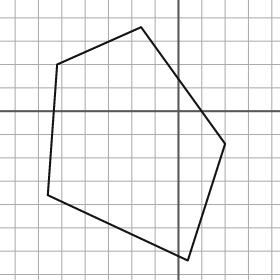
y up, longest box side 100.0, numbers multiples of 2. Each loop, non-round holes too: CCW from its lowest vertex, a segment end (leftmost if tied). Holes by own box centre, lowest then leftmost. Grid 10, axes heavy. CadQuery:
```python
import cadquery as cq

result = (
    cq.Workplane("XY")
    .moveTo(4.0, -64.0)
    .lineTo(20.0, -14.0)
    .lineTo(-16.0, 36.0)
    .lineTo(-52.0, 20.0)
    .lineTo(-56.0, -36.0)
    .close()
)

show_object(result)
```